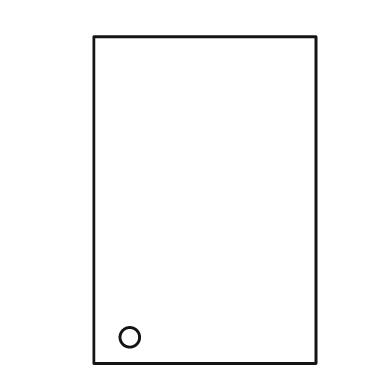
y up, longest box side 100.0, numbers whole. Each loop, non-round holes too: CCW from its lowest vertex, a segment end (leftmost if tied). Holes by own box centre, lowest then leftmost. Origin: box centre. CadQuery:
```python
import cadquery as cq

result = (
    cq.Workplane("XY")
    .moveTo(-34.0, -50.0)
    .lineTo(34.0, -50.0)
    .lineTo(34.0, 50.0)
    .lineTo(-34.0, 50.0)
    .close()
    .moveTo(-23.0, -42.0)
    .circle(3.0)
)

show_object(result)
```